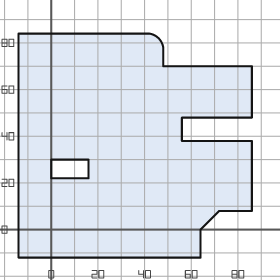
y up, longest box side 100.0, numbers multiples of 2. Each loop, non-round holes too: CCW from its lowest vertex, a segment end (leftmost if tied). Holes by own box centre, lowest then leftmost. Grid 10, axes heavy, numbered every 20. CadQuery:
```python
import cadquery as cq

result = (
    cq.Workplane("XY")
    .moveTo(-14.0, -12.0)
    .lineTo(64.0, -12.0)
    .lineTo(64.0, 0.0)
    .lineTo(72.0, 8.0)
    .lineTo(86.0, 8.0)
    .lineTo(86.0, 38.0)
    .lineTo(56.0, 38.0)
    .lineTo(56.0, 48.0)
    .lineTo(86.0, 48.0)
    .lineTo(86.0, 70.0)
    .lineTo(48.0, 70.0)
    .lineTo(48.0, 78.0)
    .threePointArc((46.0, 82.0), (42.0, 84.0))
    .lineTo(-14.0, 84.0)
    .close()
    .moveTo(0.0, 22.0)
    .lineTo(16.0, 22.0)
    .lineTo(16.0, 30.0)
    .lineTo(0.0, 30.0)
    .close()
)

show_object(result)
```